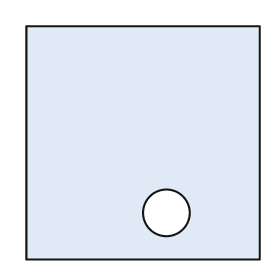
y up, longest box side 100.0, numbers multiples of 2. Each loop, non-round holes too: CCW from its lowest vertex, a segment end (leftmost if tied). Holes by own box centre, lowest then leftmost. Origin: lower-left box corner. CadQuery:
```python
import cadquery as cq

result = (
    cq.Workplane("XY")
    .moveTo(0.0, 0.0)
    .lineTo(100.0, 0.0)
    .lineTo(100.0, 100.0)
    .lineTo(0.0, 100.0)
    .close()
    .moveTo(60.0, 20.0)
    .circle(10.0)
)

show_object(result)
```